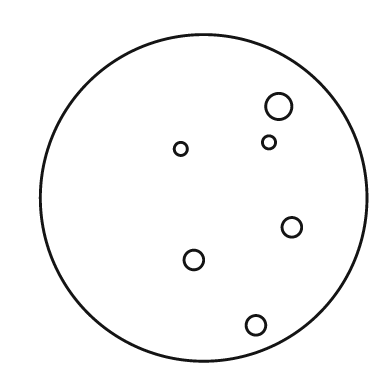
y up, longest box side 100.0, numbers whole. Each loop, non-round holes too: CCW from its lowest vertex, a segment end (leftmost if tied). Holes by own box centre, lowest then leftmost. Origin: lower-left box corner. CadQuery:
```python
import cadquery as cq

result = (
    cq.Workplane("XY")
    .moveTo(50.0, 50.0)
    .circle(50.0)
    .moveTo(66.0, 11.0)
    .circle(3.0)
    .moveTo(47.0, 31.0)
    .circle(3.0)
    .moveTo(77.0, 41.0)
    .circle(3.0)
    .moveTo(43.0, 65.0)
    .circle(2.0)
    .moveTo(70.0, 67.0)
    .circle(2.0)
    .moveTo(73.0, 78.0)
    .circle(4.0)
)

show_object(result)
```